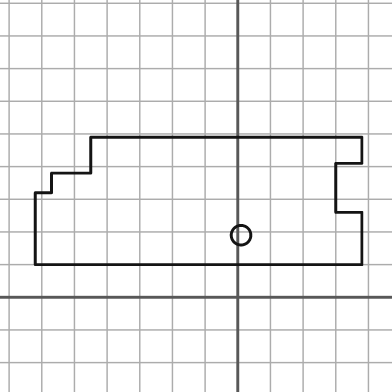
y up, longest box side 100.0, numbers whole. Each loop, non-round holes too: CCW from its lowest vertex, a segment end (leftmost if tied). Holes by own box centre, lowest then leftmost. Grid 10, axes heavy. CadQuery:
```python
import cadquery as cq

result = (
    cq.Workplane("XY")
    .moveTo(-62.0, 10.0)
    .lineTo(38.0, 10.0)
    .lineTo(38.0, 26.0)
    .lineTo(30.0, 26.0)
    .lineTo(30.0, 41.0)
    .lineTo(38.0, 41.0)
    .lineTo(38.0, 49.0)
    .lineTo(-45.0, 49.0)
    .lineTo(-45.0, 38.0)
    .lineTo(-57.0, 38.0)
    .lineTo(-57.0, 32.0)
    .lineTo(-62.0, 32.0)
    .close()
    .moveTo(1.0, 19.0)
    .circle(3.0)
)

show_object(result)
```